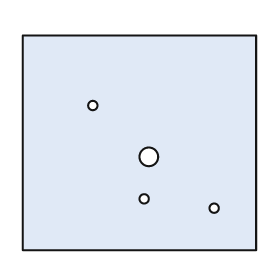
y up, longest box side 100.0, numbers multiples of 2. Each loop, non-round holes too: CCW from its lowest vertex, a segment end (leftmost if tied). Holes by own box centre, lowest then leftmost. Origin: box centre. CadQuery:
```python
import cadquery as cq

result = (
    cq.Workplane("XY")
    .moveTo(-50.0, -46.0)
    .lineTo(50.0, -46.0)
    .lineTo(50.0, 46.0)
    .lineTo(-50.0, 46.0)
    .close()
    .moveTo(32.0, -28.0)
    .circle(2.0)
    .moveTo(2.0, -24.0)
    .circle(2.0)
    .moveTo(4.0, -6.0)
    .circle(4.0)
    .moveTo(-20.0, 16.0)
    .circle(2.0)
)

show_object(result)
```